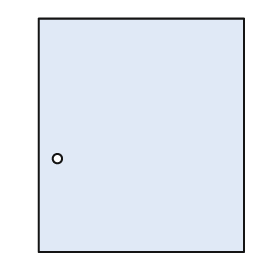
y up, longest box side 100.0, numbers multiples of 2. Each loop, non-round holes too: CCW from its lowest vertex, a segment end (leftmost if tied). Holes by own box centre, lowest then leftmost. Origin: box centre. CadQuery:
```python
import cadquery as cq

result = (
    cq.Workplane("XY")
    .moveTo(-44.0, -50.0)
    .lineTo(44.0, -50.0)
    .lineTo(44.0, 50.0)
    .lineTo(-44.0, 50.0)
    .close()
    .moveTo(-36.0, -10.0)
    .circle(2.0)
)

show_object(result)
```